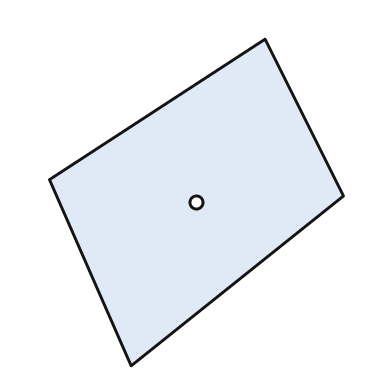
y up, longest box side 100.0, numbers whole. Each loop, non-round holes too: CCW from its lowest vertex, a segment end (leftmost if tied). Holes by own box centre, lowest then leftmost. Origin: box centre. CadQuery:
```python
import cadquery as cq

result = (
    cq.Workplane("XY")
    .moveTo(-20.0, -50.0)
    .lineTo(45.0, 2.0)
    .lineTo(21.0, 50.0)
    .lineTo(-45.0, 7.0)
    .close()
    .moveTo(0.0, 0.0)
    .circle(2.0)
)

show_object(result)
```